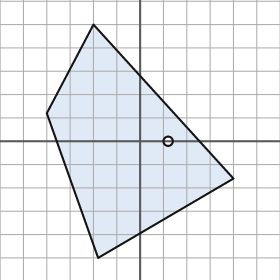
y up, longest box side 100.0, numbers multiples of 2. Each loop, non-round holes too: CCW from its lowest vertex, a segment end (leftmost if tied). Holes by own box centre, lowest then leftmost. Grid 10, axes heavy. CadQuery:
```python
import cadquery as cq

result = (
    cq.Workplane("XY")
    .moveTo(-18.0, -50.0)
    .lineTo(40.0, -16.0)
    .lineTo(-20.0, 50.0)
    .lineTo(-40.0, 12.0)
    .close()
    .moveTo(12.0, 0.0)
    .circle(2.0)
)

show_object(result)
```